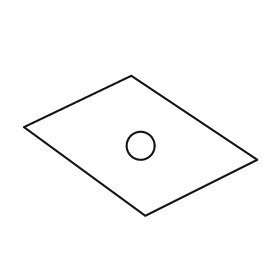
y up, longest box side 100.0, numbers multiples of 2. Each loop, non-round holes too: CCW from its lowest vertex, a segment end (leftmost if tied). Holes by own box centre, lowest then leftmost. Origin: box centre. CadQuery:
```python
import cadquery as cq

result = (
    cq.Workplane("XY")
    .moveTo(2.0, -30.0)
    .lineTo(50.0, -6.0)
    .lineTo(-4.0, 30.0)
    .lineTo(-50.0, 8.0)
    .close()
    .moveTo(0.0, 0.0)
    .circle(6.0)
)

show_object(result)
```